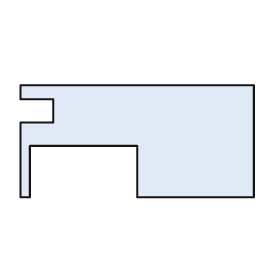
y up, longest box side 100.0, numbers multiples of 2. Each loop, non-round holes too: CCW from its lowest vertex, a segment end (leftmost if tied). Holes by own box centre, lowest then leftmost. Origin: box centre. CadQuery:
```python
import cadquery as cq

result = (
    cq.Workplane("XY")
    .moveTo(-50.0, -24.0)
    .lineTo(-46.0, -24.0)
    .lineTo(-46.0, -2.0)
    .lineTo(0.0, -2.0)
    .lineTo(0.0, -24.0)
    .lineTo(50.0, -24.0)
    .lineTo(50.0, 24.0)
    .lineTo(-50.0, 24.0)
    .lineTo(-50.0, 18.0)
    .lineTo(-36.0, 18.0)
    .lineTo(-36.0, 8.0)
    .lineTo(-50.0, 8.0)
    .close()
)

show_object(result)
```